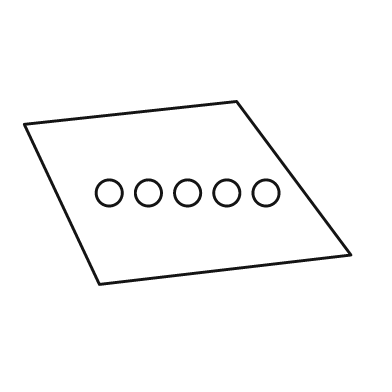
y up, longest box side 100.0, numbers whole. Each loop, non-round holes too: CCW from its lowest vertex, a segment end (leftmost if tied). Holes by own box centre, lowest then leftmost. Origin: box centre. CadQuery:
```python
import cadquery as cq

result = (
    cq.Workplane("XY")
    .moveTo(-27.0, -28.0)
    .lineTo(50.0, -19.0)
    .lineTo(15.0, 28.0)
    .lineTo(-50.0, 21.0)
    .close()
    .moveTo(-24.0, 0.0)
    .circle(4.0)
    .moveTo(-12.0, 0.0)
    .circle(4.0)
    .moveTo(0.0, 0.0)
    .circle(4.0)
    .moveTo(12.0, 0.0)
    .circle(4.0)
    .moveTo(24.0, 0.0)
    .circle(4.0)
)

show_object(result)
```